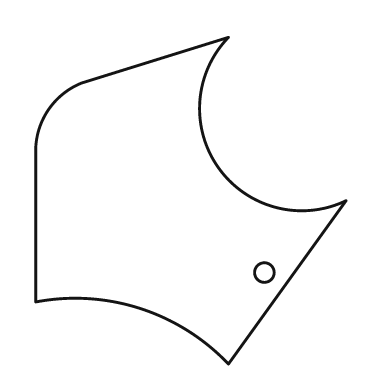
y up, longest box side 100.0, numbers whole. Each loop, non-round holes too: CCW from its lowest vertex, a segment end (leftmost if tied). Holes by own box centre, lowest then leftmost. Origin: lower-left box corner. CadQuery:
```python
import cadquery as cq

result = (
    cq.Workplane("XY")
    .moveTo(59.0, 0.0)
    .lineTo(95.0, 50.0)
    .threePointArc((56.0, 60.0), (59.0, 100.0))
    .lineTo(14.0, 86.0)
    .threePointArc((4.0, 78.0), (0.0, 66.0))
    .lineTo(0.0, 19.0)
    .threePointArc((32.0, 17.0), (59.0, 0.0))
    .close()
    .moveTo(70.0, 28.0)
    .circle(3.0)
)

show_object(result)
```